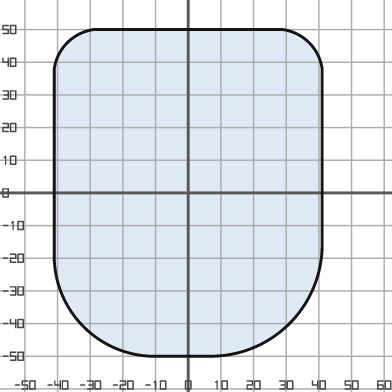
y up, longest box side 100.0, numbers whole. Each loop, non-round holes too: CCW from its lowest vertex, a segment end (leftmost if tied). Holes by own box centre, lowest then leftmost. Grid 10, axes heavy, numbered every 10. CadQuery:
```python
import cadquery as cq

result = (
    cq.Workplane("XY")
    .moveTo(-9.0, -50.0)
    .lineTo(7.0, -50.0)
    .threePointArc((31.0, -40.0), (41.0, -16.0))
    .lineTo(41.0, 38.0)
    .threePointArc((37.0, 46.0), (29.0, 50.0))
    .lineTo(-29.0, 50.0)
    .threePointArc((-37.0, 46.0), (-41.0, 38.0))
    .lineTo(-41.0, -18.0)
    .threePointArc((-32.0, -41.0), (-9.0, -50.0))
    .close()
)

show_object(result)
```